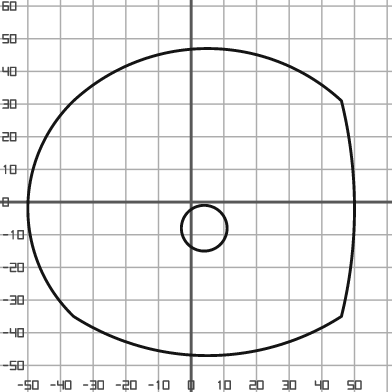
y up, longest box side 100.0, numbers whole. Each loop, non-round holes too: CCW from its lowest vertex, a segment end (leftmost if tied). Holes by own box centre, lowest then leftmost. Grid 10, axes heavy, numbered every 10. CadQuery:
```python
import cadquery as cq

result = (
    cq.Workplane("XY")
    .moveTo(-36.0, -35.0)
    .threePointArc((5.0, -47.0), (46.0, -35.0))
    .threePointArc((50.0, -2.0), (46.0, 31.0))
    .threePointArc((5.0, 47.0), (-36.0, 31.0))
    .threePointArc((-50.0, -2.0), (-36.0, -35.0))
    .close()
    .moveTo(4.0, -8.0)
    .circle(7.0)
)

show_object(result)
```